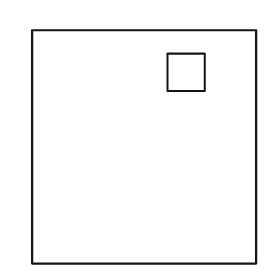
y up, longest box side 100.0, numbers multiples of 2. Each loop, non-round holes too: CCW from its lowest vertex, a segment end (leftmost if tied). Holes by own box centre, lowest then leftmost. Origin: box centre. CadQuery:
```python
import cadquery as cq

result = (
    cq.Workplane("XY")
    .moveTo(-48.0, -50.0)
    .lineTo(48.0, -50.0)
    .lineTo(48.0, 50.0)
    .lineTo(-48.0, 50.0)
    .close()
    .moveTo(10.0, 24.0)
    .lineTo(26.0, 24.0)
    .lineTo(26.0, 40.0)
    .lineTo(10.0, 40.0)
    .close()
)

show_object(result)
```